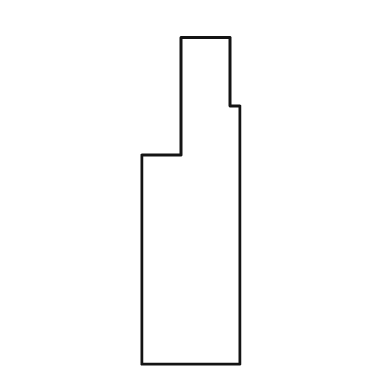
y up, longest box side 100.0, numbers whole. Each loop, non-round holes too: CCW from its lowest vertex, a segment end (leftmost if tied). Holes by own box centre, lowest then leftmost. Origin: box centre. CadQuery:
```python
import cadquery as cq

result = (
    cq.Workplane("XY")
    .moveTo(-15.0, -50.0)
    .lineTo(15.0, -50.0)
    .lineTo(15.0, 29.0)
    .lineTo(12.0, 29.0)
    .lineTo(12.0, 50.0)
    .lineTo(-3.0, 50.0)
    .lineTo(-3.0, 14.0)
    .lineTo(-15.0, 14.0)
    .close()
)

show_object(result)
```